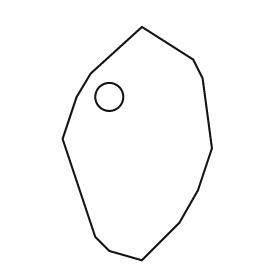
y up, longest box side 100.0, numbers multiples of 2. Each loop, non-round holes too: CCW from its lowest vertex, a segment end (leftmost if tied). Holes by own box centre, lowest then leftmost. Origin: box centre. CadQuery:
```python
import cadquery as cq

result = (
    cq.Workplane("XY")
    .moveTo(2.0, -50.0)
    .lineTo(18.0, -34.0)
    .lineTo(26.0, -20.0)
    .lineTo(32.0, -2.0)
    .lineTo(28.0, 28.0)
    .lineTo(24.0, 36.0)
    .lineTo(2.0, 50.0)
    .lineTo(-20.0, 30.0)
    .lineTo(-26.0, 20.0)
    .lineTo(-32.0, 2.0)
    .lineTo(-18.0, -40.0)
    .lineTo(-12.0, -46.0)
    .close()
    .moveTo(-12.0, 20.0)
    .circle(6.0)
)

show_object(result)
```